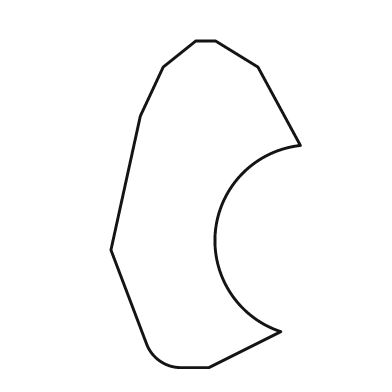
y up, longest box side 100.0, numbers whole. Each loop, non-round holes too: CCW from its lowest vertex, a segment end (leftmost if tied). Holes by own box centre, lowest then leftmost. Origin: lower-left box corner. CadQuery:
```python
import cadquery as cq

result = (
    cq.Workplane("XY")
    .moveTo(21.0, 0.0)
    .lineTo(30.0, 0.0)
    .lineTo(52.0, 11.0)
    .threePointArc((32.0, 42.0), (58.0, 68.0))
    .lineTo(45.0, 92.0)
    .lineTo(32.0, 100.0)
    .lineTo(26.0, 100.0)
    .lineTo(16.0, 92.0)
    .lineTo(9.0, 77.0)
    .lineTo(0.0, 36.0)
    .lineTo(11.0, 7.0)
    .threePointArc((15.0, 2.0), (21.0, 0.0))
    .close()
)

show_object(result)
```